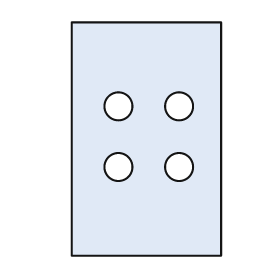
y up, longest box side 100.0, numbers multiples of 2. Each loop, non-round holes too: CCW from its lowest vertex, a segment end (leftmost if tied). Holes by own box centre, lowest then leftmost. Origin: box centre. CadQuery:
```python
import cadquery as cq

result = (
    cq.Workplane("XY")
    .moveTo(-32.0, -50.0)
    .lineTo(32.0, -50.0)
    .lineTo(32.0, 50.0)
    .lineTo(-32.0, 50.0)
    .close()
    .moveTo(-12.0, -12.0)
    .circle(6.0)
    .moveTo(14.0, -12.0)
    .circle(6.0)
    .moveTo(-12.0, 14.0)
    .circle(6.0)
    .moveTo(14.0, 14.0)
    .circle(6.0)
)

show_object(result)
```